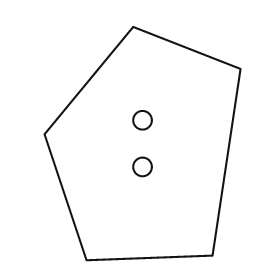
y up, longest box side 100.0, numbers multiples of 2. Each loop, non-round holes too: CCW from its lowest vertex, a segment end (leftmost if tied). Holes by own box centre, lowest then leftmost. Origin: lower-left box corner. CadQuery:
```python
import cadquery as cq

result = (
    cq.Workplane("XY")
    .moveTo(18.0, 0.0)
    .lineTo(72.0, 2.0)
    .lineTo(84.0, 82.0)
    .lineTo(38.0, 100.0)
    .lineTo(0.0, 54.0)
    .close()
    .moveTo(42.0, 40.0)
    .circle(4.0)
    .moveTo(42.0, 60.0)
    .circle(4.0)
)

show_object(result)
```